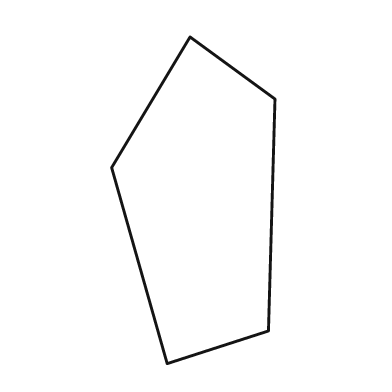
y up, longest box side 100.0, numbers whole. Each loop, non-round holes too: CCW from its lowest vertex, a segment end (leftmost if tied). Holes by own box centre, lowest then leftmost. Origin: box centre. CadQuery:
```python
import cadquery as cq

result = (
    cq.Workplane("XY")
    .moveTo(-8.0, -50.0)
    .lineTo(23.0, -40.0)
    .lineTo(25.0, 31.0)
    .lineTo(-1.0, 50.0)
    .lineTo(-25.0, 10.0)
    .close()
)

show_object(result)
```